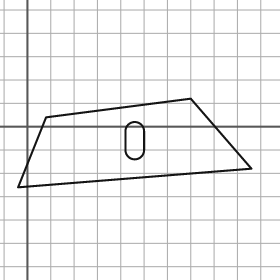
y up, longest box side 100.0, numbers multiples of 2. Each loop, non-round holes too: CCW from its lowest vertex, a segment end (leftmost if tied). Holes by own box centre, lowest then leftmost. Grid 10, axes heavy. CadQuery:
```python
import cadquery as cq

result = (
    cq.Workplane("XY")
    .moveTo(-4.0, -26.0)
    .lineTo(96.0, -18.0)
    .lineTo(70.0, 12.0)
    .lineTo(8.0, 4.0)
    .close()
    .moveTo(42.0, -10.0)
    .threePointArc((46.0, -14.0), (50.0, -10.0))
    .lineTo(50.0, -2.0)
    .threePointArc((46.0, 2.0), (42.0, -2.0))
    .close()
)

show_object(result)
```